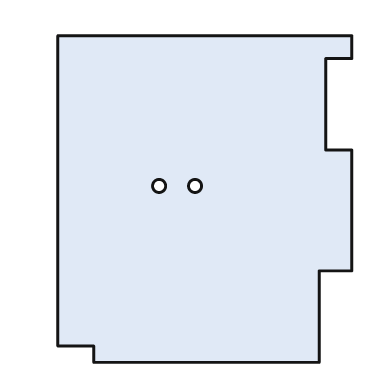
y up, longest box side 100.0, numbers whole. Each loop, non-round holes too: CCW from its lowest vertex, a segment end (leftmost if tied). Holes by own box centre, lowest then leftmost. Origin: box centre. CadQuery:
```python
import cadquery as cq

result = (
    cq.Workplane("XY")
    .moveTo(-34.0, -50.0)
    .lineTo(35.0, -50.0)
    .lineTo(35.0, -22.0)
    .lineTo(45.0, -22.0)
    .lineTo(45.0, 15.0)
    .lineTo(37.0, 15.0)
    .lineTo(37.0, 43.0)
    .lineTo(45.0, 43.0)
    .lineTo(45.0, 50.0)
    .lineTo(-45.0, 50.0)
    .lineTo(-45.0, -45.0)
    .lineTo(-34.0, -45.0)
    .close()
    .moveTo(-14.0, 4.0)
    .circle(2.0)
    .moveTo(-3.0, 4.0)
    .circle(2.0)
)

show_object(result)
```